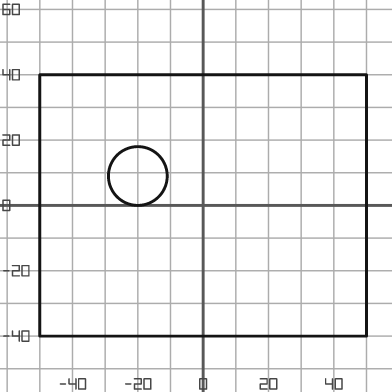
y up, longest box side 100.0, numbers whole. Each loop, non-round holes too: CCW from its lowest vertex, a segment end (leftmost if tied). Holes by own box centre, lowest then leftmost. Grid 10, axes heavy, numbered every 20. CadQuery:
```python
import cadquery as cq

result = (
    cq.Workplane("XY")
    .moveTo(-50.0, -40.0)
    .lineTo(50.0, -40.0)
    .lineTo(50.0, 40.0)
    .lineTo(-50.0, 40.0)
    .close()
    .moveTo(-20.0, 9.0)
    .circle(9.0)
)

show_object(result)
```